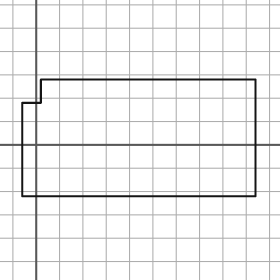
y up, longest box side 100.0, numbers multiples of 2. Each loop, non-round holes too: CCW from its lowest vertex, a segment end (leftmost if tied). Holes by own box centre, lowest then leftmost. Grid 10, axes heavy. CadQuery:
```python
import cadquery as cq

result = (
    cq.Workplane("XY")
    .moveTo(-6.0, -22.0)
    .lineTo(94.0, -22.0)
    .lineTo(94.0, 28.0)
    .lineTo(2.0, 28.0)
    .lineTo(2.0, 18.0)
    .lineTo(-6.0, 18.0)
    .close()
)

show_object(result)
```